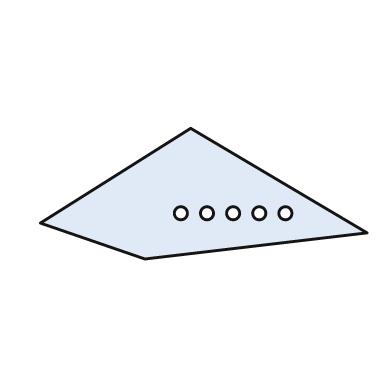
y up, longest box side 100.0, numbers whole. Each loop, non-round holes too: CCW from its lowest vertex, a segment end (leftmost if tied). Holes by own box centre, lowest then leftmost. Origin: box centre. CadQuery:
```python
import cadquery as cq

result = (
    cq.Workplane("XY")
    .moveTo(-18.0, -20.0)
    .lineTo(50.0, -12.0)
    .lineTo(-4.0, 20.0)
    .lineTo(-50.0, -9.0)
    .close()
    .moveTo(-7.0, -6.0)
    .circle(2.0)
    .moveTo(1.0, -6.0)
    .circle(2.0)
    .moveTo(9.0, -6.0)
    .circle(2.0)
    .moveTo(17.0, -6.0)
    .circle(2.0)
    .moveTo(25.0, -6.0)
    .circle(2.0)
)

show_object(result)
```